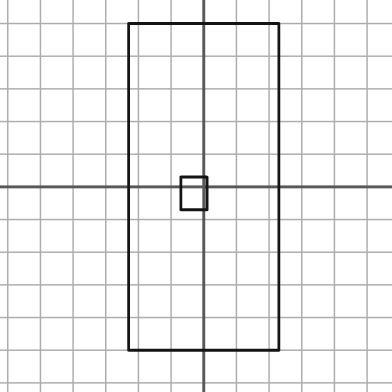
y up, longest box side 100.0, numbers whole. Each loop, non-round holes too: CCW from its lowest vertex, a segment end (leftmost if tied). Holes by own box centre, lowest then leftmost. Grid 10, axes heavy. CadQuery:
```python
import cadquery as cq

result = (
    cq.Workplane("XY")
    .moveTo(-23.0, -50.0)
    .lineTo(23.0, -50.0)
    .lineTo(23.0, 50.0)
    .lineTo(-23.0, 50.0)
    .close()
    .moveTo(-7.0, -7.0)
    .lineTo(1.0, -7.0)
    .lineTo(1.0, 3.0)
    .lineTo(-7.0, 3.0)
    .close()
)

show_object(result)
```